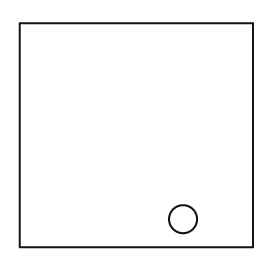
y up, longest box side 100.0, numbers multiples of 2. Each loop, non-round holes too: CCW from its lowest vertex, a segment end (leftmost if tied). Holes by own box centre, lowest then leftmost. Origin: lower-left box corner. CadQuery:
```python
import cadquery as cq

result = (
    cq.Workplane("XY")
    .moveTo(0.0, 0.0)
    .lineTo(100.0, 0.0)
    .lineTo(100.0, 96.0)
    .lineTo(0.0, 96.0)
    .close()
    .moveTo(70.0, 12.0)
    .circle(6.0)
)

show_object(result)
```